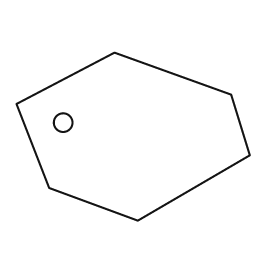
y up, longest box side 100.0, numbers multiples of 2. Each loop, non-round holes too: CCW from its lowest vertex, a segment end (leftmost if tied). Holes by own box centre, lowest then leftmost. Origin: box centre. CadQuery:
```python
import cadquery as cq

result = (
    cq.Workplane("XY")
    .moveTo(2.0, -36.0)
    .lineTo(50.0, -8.0)
    .lineTo(42.0, 18.0)
    .lineTo(-8.0, 36.0)
    .lineTo(-50.0, 14.0)
    .lineTo(-36.0, -22.0)
    .close()
    .moveTo(-30.0, 6.0)
    .circle(4.0)
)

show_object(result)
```